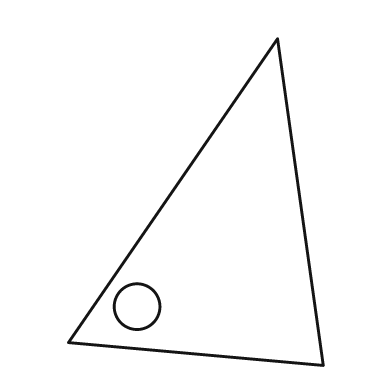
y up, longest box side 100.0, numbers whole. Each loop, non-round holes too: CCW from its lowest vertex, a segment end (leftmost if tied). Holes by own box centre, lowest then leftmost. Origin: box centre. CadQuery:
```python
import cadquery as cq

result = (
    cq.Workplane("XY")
    .moveTo(39.0, -50.0)
    .lineTo(25.0, 50.0)
    .lineTo(-39.0, -43.0)
    .close()
    .moveTo(-18.0, -32.0)
    .circle(7.0)
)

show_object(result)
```